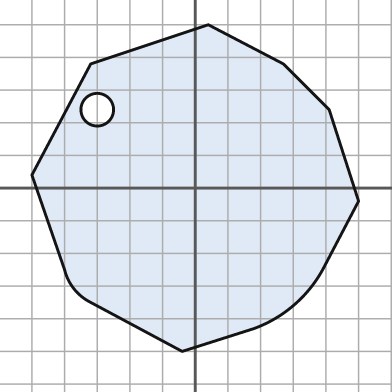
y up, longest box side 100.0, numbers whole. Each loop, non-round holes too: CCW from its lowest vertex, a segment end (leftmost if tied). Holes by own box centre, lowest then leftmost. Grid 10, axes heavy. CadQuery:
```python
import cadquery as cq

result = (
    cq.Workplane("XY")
    .moveTo(-4.0, -50.0)
    .lineTo(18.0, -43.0)
    .threePointArc((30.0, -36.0), (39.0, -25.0))
    .lineTo(50.0, -4.0)
    .lineTo(41.0, 24.0)
    .lineTo(27.0, 38.0)
    .lineTo(4.0, 50.0)
    .lineTo(-32.0, 38.0)
    .lineTo(-50.0, 4.0)
    .lineTo(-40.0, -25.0)
    .threePointArc((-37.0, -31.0), (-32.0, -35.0))
    .close()
    .moveTo(-30.0, 24.0)
    .circle(5.0)
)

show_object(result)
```